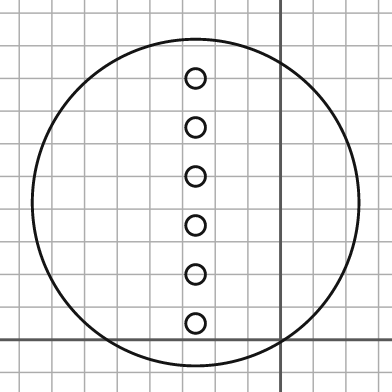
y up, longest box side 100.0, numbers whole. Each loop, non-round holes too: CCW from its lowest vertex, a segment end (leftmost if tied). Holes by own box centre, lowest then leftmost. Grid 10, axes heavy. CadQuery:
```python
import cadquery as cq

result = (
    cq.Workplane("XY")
    .moveTo(-26.0, 42.0)
    .circle(50.0)
    .moveTo(-26.0, 5.0)
    .circle(3.0)
    .moveTo(-26.0, 20.0)
    .circle(3.0)
    .moveTo(-26.0, 35.0)
    .circle(3.0)
    .moveTo(-26.0, 50.0)
    .circle(3.0)
    .moveTo(-26.0, 65.0)
    .circle(3.0)
    .moveTo(-26.0, 80.0)
    .circle(3.0)
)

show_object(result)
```